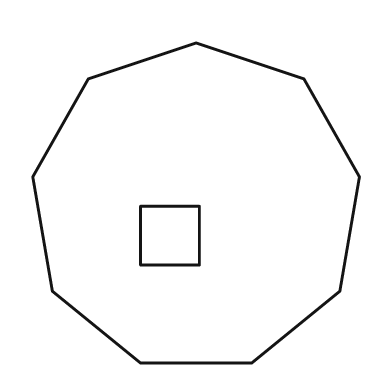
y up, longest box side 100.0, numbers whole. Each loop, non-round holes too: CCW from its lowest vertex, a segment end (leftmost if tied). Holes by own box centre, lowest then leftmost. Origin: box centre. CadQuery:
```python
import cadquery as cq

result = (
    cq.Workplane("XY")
    .moveTo(-17.0, -49.0)
    .lineTo(17.0, -49.0)
    .lineTo(44.0, -27.0)
    .lineTo(50.0, 8.0)
    .lineTo(33.0, 38.0)
    .lineTo(0.0, 49.0)
    .lineTo(-33.0, 38.0)
    .lineTo(-50.0, 8.0)
    .lineTo(-44.0, -27.0)
    .close()
    .moveTo(-17.0, -19.0)
    .lineTo(1.0, -19.0)
    .lineTo(1.0, -1.0)
    .lineTo(-17.0, -1.0)
    .close()
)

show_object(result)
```